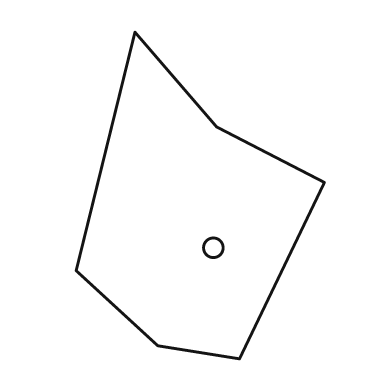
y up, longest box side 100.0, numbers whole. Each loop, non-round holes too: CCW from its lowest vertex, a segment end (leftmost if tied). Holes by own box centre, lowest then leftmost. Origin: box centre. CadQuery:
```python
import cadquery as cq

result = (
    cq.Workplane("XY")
    .moveTo(12.0, -50.0)
    .lineTo(38.0, 4.0)
    .lineTo(5.0, 21.0)
    .lineTo(-20.0, 50.0)
    .lineTo(-38.0, -23.0)
    .lineTo(-13.0, -46.0)
    .close()
    .moveTo(4.0, -16.0)
    .circle(3.0)
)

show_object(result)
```